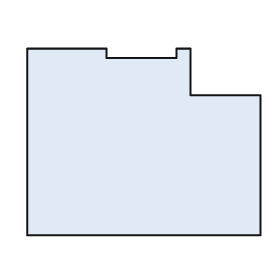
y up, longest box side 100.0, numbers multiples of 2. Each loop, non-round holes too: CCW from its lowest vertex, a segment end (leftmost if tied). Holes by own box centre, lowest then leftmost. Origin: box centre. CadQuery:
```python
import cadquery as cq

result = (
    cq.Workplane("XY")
    .moveTo(-50.0, -40.0)
    .lineTo(50.0, -40.0)
    .lineTo(50.0, 20.0)
    .lineTo(20.0, 20.0)
    .lineTo(20.0, 40.0)
    .lineTo(14.0, 40.0)
    .lineTo(14.0, 36.0)
    .lineTo(-16.0, 36.0)
    .lineTo(-16.0, 40.0)
    .lineTo(-50.0, 40.0)
    .close()
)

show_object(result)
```